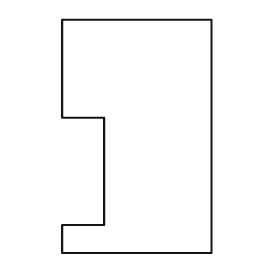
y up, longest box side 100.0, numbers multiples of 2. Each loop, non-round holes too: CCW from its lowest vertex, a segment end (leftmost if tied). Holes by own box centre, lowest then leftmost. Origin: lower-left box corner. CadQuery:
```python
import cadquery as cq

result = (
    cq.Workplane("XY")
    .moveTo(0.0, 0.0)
    .lineTo(64.0, 0.0)
    .lineTo(64.0, 100.0)
    .lineTo(0.0, 100.0)
    .lineTo(0.0, 58.0)
    .lineTo(18.0, 58.0)
    .lineTo(18.0, 12.0)
    .lineTo(0.0, 12.0)
    .close()
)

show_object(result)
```